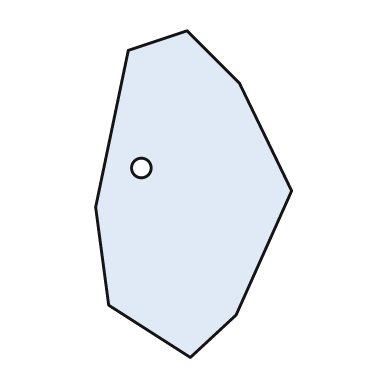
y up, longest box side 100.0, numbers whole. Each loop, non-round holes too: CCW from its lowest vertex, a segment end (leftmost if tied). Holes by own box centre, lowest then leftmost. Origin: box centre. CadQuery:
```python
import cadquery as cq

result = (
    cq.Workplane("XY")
    .moveTo(-1.0, -50.0)
    .lineTo(13.0, -37.0)
    .lineTo(30.0, 1.0)
    .lineTo(14.0, 34.0)
    .lineTo(-2.0, 50.0)
    .lineTo(-20.0, 44.0)
    .lineTo(-30.0, -4.0)
    .lineTo(-26.0, -34.0)
    .close()
    .moveTo(-16.0, 8.0)
    .circle(3.0)
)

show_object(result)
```